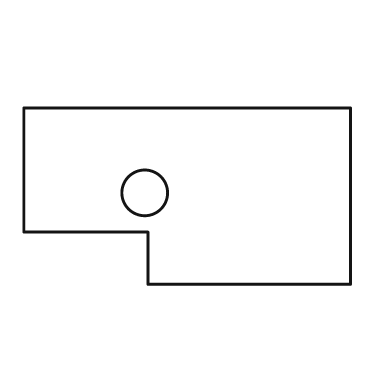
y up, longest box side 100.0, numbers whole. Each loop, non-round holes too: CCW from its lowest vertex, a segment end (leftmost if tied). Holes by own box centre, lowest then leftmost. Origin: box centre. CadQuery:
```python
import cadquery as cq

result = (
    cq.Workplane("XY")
    .moveTo(-12.0, -27.0)
    .lineTo(50.0, -27.0)
    .lineTo(50.0, 27.0)
    .lineTo(-50.0, 27.0)
    .lineTo(-50.0, -11.0)
    .lineTo(-12.0, -11.0)
    .close()
    .moveTo(-13.0, 1.0)
    .circle(7.0)
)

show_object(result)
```